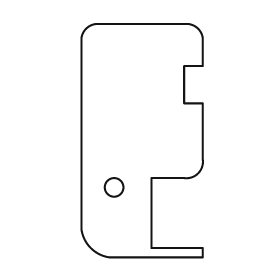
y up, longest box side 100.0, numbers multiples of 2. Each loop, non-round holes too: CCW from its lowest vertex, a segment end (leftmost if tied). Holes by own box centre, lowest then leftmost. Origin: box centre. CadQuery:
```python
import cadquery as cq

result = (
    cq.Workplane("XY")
    .moveTo(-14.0, -50.0)
    .lineTo(26.0, -50.0)
    .lineTo(26.0, -46.0)
    .lineTo(4.0, -46.0)
    .lineTo(4.0, -16.0)
    .lineTo(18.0, -16.0)
    .threePointArc((24.0, -14.0), (26.0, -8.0))
    .lineTo(26.0, 16.0)
    .lineTo(18.0, 16.0)
    .lineTo(18.0, 32.0)
    .lineTo(26.0, 32.0)
    .lineTo(26.0, 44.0)
    .threePointArc((24.0, 48.0), (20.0, 50.0))
    .lineTo(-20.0, 50.0)
    .threePointArc((-24.0, 48.0), (-26.0, 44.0))
    .lineTo(-26.0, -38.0)
    .threePointArc((-22.0, -46.0), (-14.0, -50.0))
    .close()
    .moveTo(-12.0, -20.0)
    .circle(4.0)
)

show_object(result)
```